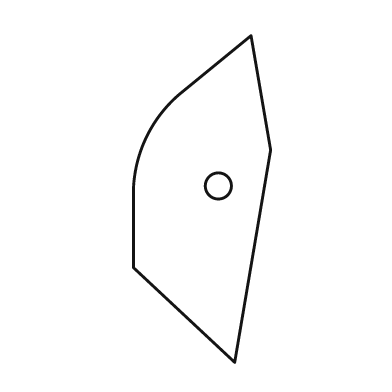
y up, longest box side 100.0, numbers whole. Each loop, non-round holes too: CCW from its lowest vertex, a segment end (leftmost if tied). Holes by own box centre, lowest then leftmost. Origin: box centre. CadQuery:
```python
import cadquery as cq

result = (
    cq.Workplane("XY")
    .moveTo(10.0, -50.0)
    .lineTo(21.0, 15.0)
    .lineTo(15.0, 50.0)
    .lineTo(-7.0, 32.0)
    .threePointArc((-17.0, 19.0), (-21.0, 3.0))
    .lineTo(-21.0, -21.0)
    .close()
    .moveTo(5.0, 4.0)
    .circle(4.0)
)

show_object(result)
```